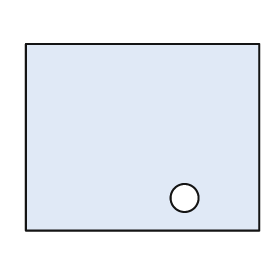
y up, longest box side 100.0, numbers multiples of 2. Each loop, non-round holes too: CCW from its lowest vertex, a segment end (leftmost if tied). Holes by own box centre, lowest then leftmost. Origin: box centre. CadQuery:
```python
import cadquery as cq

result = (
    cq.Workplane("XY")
    .moveTo(-50.0, -40.0)
    .lineTo(50.0, -40.0)
    .lineTo(50.0, 40.0)
    .lineTo(-50.0, 40.0)
    .close()
    .moveTo(18.0, -26.0)
    .circle(6.0)
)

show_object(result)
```